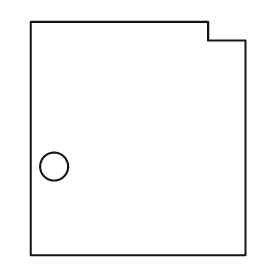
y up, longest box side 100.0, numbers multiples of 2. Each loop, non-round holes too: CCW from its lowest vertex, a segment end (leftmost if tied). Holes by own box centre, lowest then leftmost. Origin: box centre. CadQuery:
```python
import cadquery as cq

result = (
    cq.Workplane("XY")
    .moveTo(-46.0, -50.0)
    .lineTo(46.0, -50.0)
    .lineTo(46.0, 42.0)
    .lineTo(30.0, 42.0)
    .lineTo(30.0, 50.0)
    .lineTo(-46.0, 50.0)
    .close()
    .moveTo(-36.0, -12.0)
    .circle(6.0)
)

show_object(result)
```